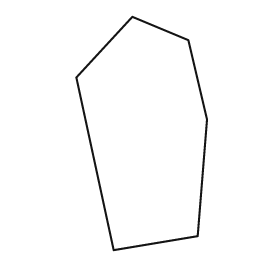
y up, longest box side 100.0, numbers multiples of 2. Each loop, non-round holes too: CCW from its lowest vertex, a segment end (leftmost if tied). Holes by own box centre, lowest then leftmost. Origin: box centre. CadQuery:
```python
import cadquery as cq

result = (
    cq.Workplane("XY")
    .moveTo(-12.0, -50.0)
    .lineTo(24.0, -44.0)
    .lineTo(28.0, 6.0)
    .lineTo(20.0, 40.0)
    .lineTo(-4.0, 50.0)
    .lineTo(-28.0, 24.0)
    .close()
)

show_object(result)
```